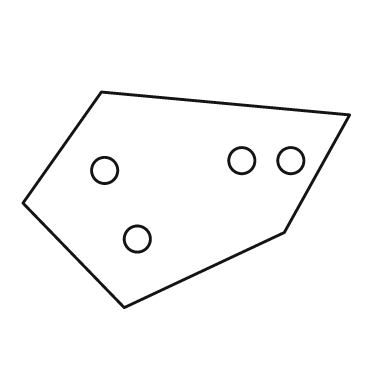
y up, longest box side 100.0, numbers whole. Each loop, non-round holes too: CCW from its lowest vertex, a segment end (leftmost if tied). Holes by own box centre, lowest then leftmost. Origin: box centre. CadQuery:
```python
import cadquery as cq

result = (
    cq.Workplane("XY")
    .moveTo(-19.0, -33.0)
    .lineTo(30.0, -10.0)
    .lineTo(50.0, 26.0)
    .lineTo(-26.0, 33.0)
    .lineTo(-50.0, -1.0)
    .close()
    .moveTo(-15.0, -12.0)
    .circle(4.0)
    .moveTo(-25.0, 9.0)
    .circle(4.0)
    .moveTo(17.0, 12.0)
    .circle(4.0)
    .moveTo(32.0, 12.0)
    .circle(4.0)
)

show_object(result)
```